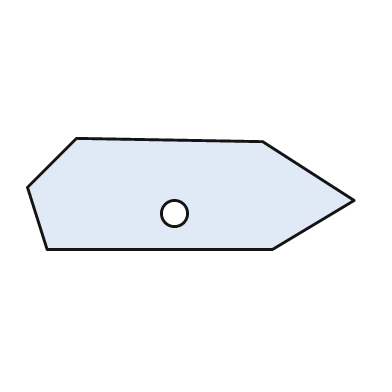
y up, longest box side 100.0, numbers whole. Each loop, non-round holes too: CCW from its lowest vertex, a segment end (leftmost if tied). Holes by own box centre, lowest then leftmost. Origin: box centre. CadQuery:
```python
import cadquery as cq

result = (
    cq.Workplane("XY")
    .moveTo(-44.0, -17.0)
    .lineTo(25.0, -17.0)
    .lineTo(50.0, -2.0)
    .lineTo(22.0, 16.0)
    .lineTo(-35.0, 17.0)
    .lineTo(-50.0, 2.0)
    .close()
    .moveTo(-5.0, -6.0)
    .circle(4.0)
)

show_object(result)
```